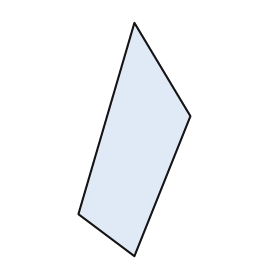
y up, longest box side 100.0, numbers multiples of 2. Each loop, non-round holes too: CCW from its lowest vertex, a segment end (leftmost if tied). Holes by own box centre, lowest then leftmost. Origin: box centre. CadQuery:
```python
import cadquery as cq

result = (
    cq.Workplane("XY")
    .moveTo(0.0, -50.0)
    .lineTo(24.0, 10.0)
    .lineTo(0.0, 50.0)
    .lineTo(-24.0, -32.0)
    .close()
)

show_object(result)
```